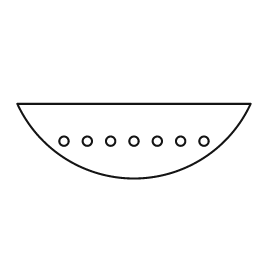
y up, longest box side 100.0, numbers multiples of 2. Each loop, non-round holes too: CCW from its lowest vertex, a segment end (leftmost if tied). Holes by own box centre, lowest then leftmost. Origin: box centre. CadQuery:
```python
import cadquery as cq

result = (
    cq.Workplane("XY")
    .moveTo(-50.0, 16.0)
    .threePointArc((0.0, -16.0), (50.0, 16.0))
    .close()
    .moveTo(-30.0, 0.0)
    .circle(2.0)
    .moveTo(-20.0, 0.0)
    .circle(2.0)
    .moveTo(-10.0, 0.0)
    .circle(2.0)
    .moveTo(0.0, 0.0)
    .circle(2.0)
    .moveTo(10.0, 0.0)
    .circle(2.0)
    .moveTo(20.0, 0.0)
    .circle(2.0)
    .moveTo(30.0, 0.0)
    .circle(2.0)
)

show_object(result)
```